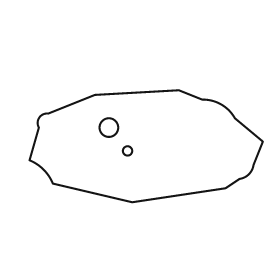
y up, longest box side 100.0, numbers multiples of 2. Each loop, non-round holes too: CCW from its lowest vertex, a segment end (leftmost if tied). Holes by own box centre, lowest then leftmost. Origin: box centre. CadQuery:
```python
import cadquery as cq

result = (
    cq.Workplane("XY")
    .moveTo(-6.0, -24.0)
    .lineTo(34.0, -18.0)
    .lineTo(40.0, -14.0)
    .threePointArc((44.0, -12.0), (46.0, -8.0))
    .lineTo(50.0, 2.0)
    .lineTo(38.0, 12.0)
    .threePointArc((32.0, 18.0), (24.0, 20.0))
    .lineTo(14.0, 24.0)
    .lineTo(-22.0, 22.0)
    .lineTo(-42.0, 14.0)
    .threePointArc((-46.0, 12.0), (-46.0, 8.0))
    .lineTo(-50.0, -6.0)
    .threePointArc((-44.0, -10.0), (-40.0, -16.0))
    .close()
    .moveTo(-8.0, -2.0)
    .circle(2.0)
    .moveTo(-16.0, 8.0)
    .circle(4.0)
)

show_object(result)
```